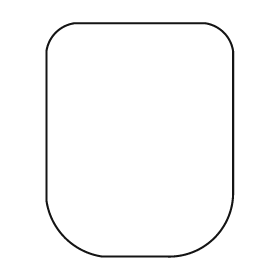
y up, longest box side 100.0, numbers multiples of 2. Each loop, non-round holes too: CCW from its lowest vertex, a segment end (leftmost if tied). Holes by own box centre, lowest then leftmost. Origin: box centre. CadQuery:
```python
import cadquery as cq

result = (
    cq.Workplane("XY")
    .moveTo(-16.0, -50.0)
    .lineTo(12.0, -50.0)
    .threePointArc((32.0, -42.0), (40.0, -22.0))
    .lineTo(40.0, 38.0)
    .threePointArc((36.0, 46.0), (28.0, 50.0))
    .lineTo(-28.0, 50.0)
    .threePointArc((-36.0, 46.0), (-40.0, 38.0))
    .lineTo(-40.0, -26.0)
    .threePointArc((-32.0, -42.0), (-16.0, -50.0))
    .close()
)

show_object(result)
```